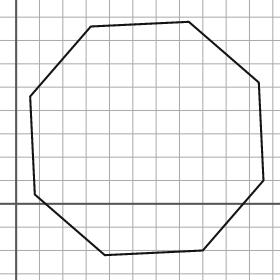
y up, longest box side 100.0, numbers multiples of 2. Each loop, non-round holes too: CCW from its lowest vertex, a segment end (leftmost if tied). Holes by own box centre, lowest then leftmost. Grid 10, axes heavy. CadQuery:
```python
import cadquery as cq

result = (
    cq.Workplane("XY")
    .moveTo(38.0, -22.0)
    .lineTo(80.0, -20.0)
    .lineTo(106.0, 10.0)
    .lineTo(104.0, 52.0)
    .lineTo(74.0, 78.0)
    .lineTo(32.0, 76.0)
    .lineTo(6.0, 46.0)
    .lineTo(8.0, 4.0)
    .close()
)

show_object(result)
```